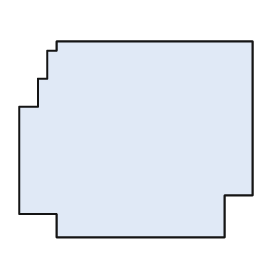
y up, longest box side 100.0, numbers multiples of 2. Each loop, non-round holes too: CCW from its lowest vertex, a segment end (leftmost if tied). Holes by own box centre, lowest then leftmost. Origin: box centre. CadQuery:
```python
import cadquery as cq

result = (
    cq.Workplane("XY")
    .moveTo(-34.0, -42.0)
    .lineTo(38.0, -42.0)
    .lineTo(38.0, -24.0)
    .lineTo(50.0, -24.0)
    .lineTo(50.0, 42.0)
    .lineTo(-34.0, 42.0)
    .lineTo(-34.0, 38.0)
    .lineTo(-38.0, 38.0)
    .lineTo(-38.0, 26.0)
    .lineTo(-42.0, 26.0)
    .lineTo(-42.0, 14.0)
    .lineTo(-50.0, 14.0)
    .lineTo(-50.0, -32.0)
    .lineTo(-34.0, -32.0)
    .close()
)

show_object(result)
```